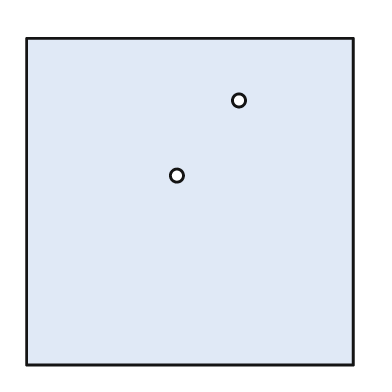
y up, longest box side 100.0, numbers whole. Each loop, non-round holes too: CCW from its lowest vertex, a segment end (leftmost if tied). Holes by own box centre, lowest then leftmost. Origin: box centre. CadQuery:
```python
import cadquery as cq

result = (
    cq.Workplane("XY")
    .moveTo(-50.0, -50.0)
    .lineTo(50.0, -50.0)
    .lineTo(50.0, 50.0)
    .lineTo(-50.0, 50.0)
    .close()
    .moveTo(-4.0, 8.0)
    .circle(2.0)
    .moveTo(15.0, 31.0)
    .circle(2.0)
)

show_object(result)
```